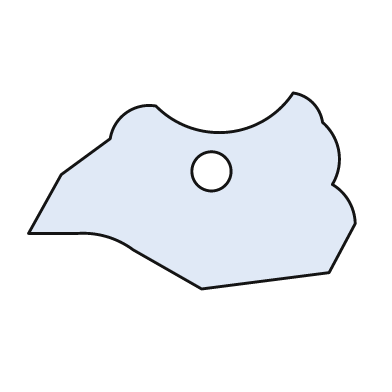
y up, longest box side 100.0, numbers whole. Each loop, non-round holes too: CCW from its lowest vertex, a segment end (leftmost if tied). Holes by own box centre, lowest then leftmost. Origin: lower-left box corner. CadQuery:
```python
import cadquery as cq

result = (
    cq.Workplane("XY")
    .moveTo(53.0, 0.0)
    .lineTo(92.0, 5.0)
    .lineTo(100.0, 20.0)
    .threePointArc((98.0, 27.0), (93.0, 32.0))
    .threePointArc((95.0, 42.0), (90.0, 51.0))
    .threePointArc((87.0, 57.0), (81.0, 60.0))
    .threePointArc((61.0, 48.0), (39.0, 56.0))
    .threePointArc((30.0, 54.0), (25.0, 46.0))
    .lineTo(10.0, 35.0)
    .lineTo(0.0, 17.0)
    .lineTo(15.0, 17.0)
    .threePointArc((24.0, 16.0), (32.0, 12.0))
    .close()
    .moveTo(56.0, 36.0)
    .circle(6.0)
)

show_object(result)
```